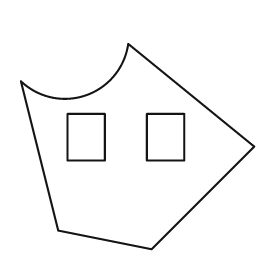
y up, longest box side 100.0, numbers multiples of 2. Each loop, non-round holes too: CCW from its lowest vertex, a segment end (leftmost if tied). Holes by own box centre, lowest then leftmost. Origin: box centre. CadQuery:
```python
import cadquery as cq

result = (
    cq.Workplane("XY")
    .moveTo(6.0, -44.0)
    .lineTo(50.0, 0.0)
    .lineTo(-4.0, 44.0)
    .threePointArc((-22.0, 22.0), (-50.0, 28.0))
    .lineTo(-34.0, -36.0)
    .close()
    .moveTo(-30.0, -6.0)
    .lineTo(-14.0, -6.0)
    .lineTo(-14.0, 14.0)
    .lineTo(-30.0, 14.0)
    .close()
    .moveTo(4.0, -6.0)
    .lineTo(20.0, -6.0)
    .lineTo(20.0, 14.0)
    .lineTo(4.0, 14.0)
    .close()
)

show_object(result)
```